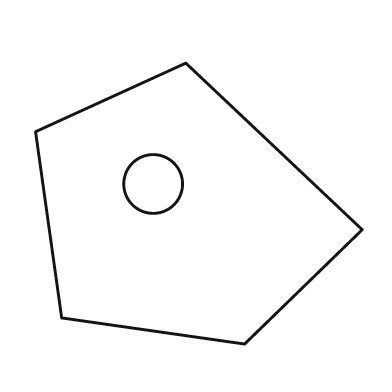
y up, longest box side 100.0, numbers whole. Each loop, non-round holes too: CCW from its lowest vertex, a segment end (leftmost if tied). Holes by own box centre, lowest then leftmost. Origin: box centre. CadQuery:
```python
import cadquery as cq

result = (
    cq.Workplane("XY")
    .moveTo(14.0, -43.0)
    .lineTo(50.0, -8.0)
    .lineTo(-4.0, 43.0)
    .lineTo(-50.0, 22.0)
    .lineTo(-42.0, -35.0)
    .close()
    .moveTo(-14.0, 6.0)
    .circle(9.0)
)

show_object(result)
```